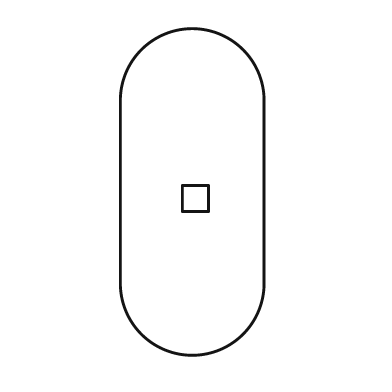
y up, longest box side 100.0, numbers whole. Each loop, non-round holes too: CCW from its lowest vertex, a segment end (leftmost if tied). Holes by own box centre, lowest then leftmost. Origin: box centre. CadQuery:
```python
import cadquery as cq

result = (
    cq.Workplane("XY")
    .moveTo(-22.0, -28.0)
    .threePointArc((0.0, -50.0), (22.0, -28.0))
    .lineTo(22.0, 28.0)
    .threePointArc((0.0, 50.0), (-22.0, 28.0))
    .close()
    .moveTo(-3.0, -6.0)
    .lineTo(5.0, -6.0)
    .lineTo(5.0, 2.0)
    .lineTo(-3.0, 2.0)
    .close()
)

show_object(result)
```